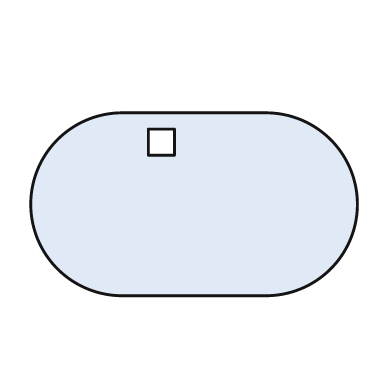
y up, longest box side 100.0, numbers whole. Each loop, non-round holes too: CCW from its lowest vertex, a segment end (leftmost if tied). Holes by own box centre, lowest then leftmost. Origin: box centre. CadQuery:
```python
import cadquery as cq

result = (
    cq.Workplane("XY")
    .moveTo(-22.0, -28.0)
    .lineTo(22.0, -28.0)
    .threePointArc((50.0, 0.0), (22.0, 28.0))
    .lineTo(-22.0, 28.0)
    .threePointArc((-50.0, 0.0), (-22.0, -28.0))
    .close()
    .moveTo(-14.0, 15.0)
    .lineTo(-6.0, 15.0)
    .lineTo(-6.0, 23.0)
    .lineTo(-14.0, 23.0)
    .close()
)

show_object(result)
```